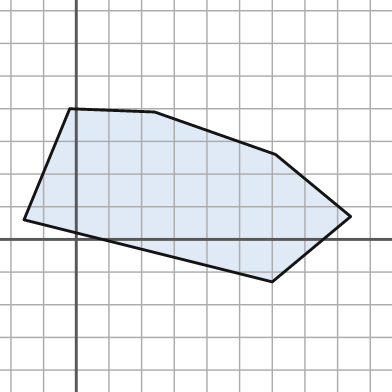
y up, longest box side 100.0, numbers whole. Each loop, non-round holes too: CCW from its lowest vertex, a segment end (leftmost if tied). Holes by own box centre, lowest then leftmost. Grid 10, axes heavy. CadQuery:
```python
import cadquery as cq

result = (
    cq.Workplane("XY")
    .moveTo(60.0, -13.0)
    .lineTo(84.0, 7.0)
    .lineTo(61.0, 26.0)
    .lineTo(24.0, 39.0)
    .lineTo(-2.0, 40.0)
    .lineTo(-16.0, 6.0)
    .close()
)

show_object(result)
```